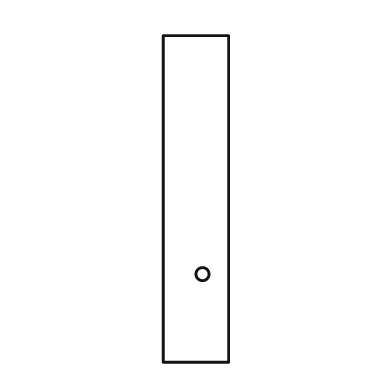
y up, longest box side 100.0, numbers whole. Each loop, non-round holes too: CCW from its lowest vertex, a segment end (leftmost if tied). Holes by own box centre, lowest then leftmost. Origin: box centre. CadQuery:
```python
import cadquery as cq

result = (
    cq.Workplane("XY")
    .moveTo(-10.0, -50.0)
    .lineTo(10.0, -50.0)
    .lineTo(10.0, 50.0)
    .lineTo(-10.0, 50.0)
    .close()
    .moveTo(2.0, -23.0)
    .circle(2.0)
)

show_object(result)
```